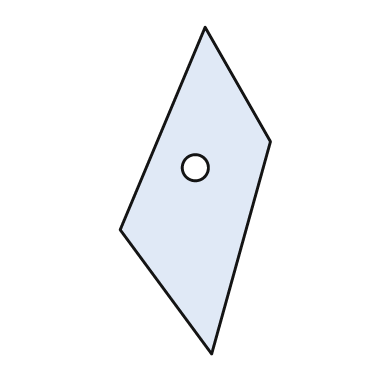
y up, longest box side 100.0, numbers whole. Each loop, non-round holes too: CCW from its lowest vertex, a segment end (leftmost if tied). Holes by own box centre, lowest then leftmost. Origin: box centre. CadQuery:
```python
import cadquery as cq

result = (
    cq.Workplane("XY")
    .moveTo(5.0, -50.0)
    .lineTo(23.0, 15.0)
    .lineTo(3.0, 50.0)
    .lineTo(-23.0, -12.0)
    .close()
    .moveTo(0.0, 7.0)
    .circle(4.0)
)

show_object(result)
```